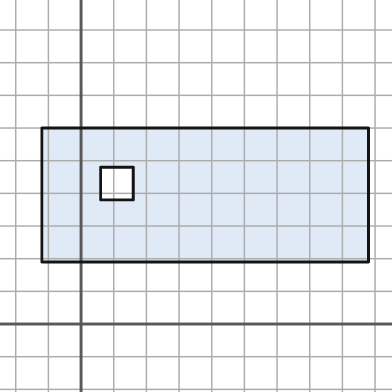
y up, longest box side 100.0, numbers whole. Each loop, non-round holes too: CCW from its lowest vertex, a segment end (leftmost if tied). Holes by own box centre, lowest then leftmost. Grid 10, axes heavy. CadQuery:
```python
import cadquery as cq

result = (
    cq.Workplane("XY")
    .moveTo(-12.0, 19.0)
    .lineTo(88.0, 19.0)
    .lineTo(88.0, 60.0)
    .lineTo(-12.0, 60.0)
    .close()
    .moveTo(6.0, 38.0)
    .lineTo(16.0, 38.0)
    .lineTo(16.0, 48.0)
    .lineTo(6.0, 48.0)
    .close()
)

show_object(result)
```